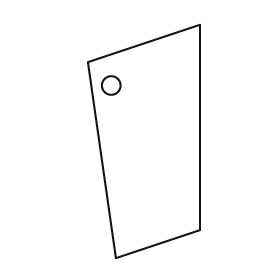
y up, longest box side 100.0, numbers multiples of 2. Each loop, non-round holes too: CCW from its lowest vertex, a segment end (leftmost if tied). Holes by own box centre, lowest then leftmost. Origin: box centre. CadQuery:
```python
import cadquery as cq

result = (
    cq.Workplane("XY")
    .moveTo(-12.0, -50.0)
    .lineTo(24.0, -38.0)
    .lineTo(24.0, 50.0)
    .lineTo(-24.0, 34.0)
    .close()
    .moveTo(-14.0, 24.0)
    .circle(4.0)
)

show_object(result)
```